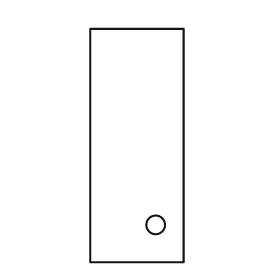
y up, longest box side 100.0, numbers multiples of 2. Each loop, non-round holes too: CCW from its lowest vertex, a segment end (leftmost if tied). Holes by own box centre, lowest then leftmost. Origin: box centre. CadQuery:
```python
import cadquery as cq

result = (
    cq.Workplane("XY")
    .moveTo(-20.0, -50.0)
    .lineTo(20.0, -50.0)
    .lineTo(20.0, 50.0)
    .lineTo(-20.0, 50.0)
    .close()
    .moveTo(8.0, -34.0)
    .circle(4.0)
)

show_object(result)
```